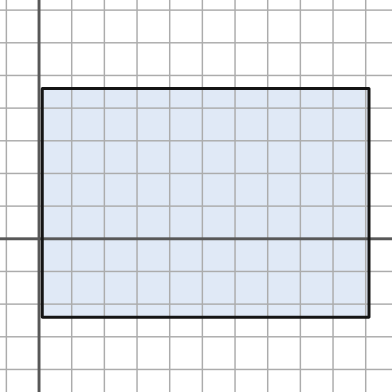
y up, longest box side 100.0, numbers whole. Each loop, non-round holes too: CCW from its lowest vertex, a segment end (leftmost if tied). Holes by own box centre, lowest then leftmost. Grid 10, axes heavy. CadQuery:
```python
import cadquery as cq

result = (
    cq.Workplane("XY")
    .moveTo(1.0, -24.0)
    .lineTo(101.0, -24.0)
    .lineTo(101.0, 46.0)
    .lineTo(1.0, 46.0)
    .close()
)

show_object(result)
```